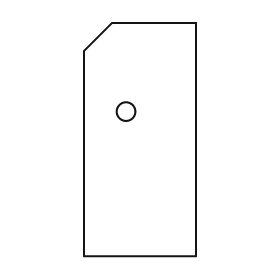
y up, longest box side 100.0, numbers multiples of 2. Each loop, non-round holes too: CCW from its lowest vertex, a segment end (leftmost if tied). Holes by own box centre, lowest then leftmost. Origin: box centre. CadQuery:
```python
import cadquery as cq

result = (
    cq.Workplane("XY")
    .moveTo(-24.0, -50.0)
    .lineTo(24.0, -50.0)
    .lineTo(24.0, 50.0)
    .lineTo(-12.0, 50.0)
    .lineTo(-24.0, 38.0)
    .close()
    .moveTo(-6.0, 12.0)
    .circle(4.0)
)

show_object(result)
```